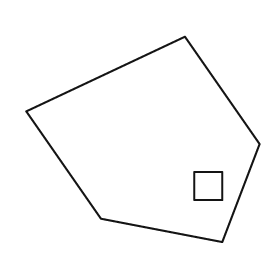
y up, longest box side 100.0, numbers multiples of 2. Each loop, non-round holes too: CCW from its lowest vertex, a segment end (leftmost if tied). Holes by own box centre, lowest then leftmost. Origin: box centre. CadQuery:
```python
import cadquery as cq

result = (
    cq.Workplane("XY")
    .moveTo(34.0, -44.0)
    .lineTo(50.0, -2.0)
    .lineTo(18.0, 44.0)
    .lineTo(-50.0, 12.0)
    .lineTo(-18.0, -34.0)
    .close()
    .moveTo(22.0, -26.0)
    .lineTo(34.0, -26.0)
    .lineTo(34.0, -14.0)
    .lineTo(22.0, -14.0)
    .close()
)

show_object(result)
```